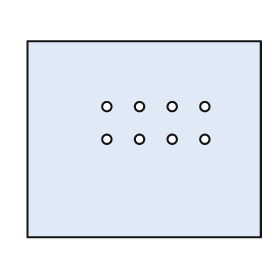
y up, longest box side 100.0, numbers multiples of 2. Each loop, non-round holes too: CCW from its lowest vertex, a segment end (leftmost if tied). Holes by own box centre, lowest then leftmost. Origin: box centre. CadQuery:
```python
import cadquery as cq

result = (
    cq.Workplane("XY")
    .moveTo(-50.0, -42.0)
    .lineTo(50.0, -42.0)
    .lineTo(50.0, 42.0)
    .lineTo(-50.0, 42.0)
    .close()
    .moveTo(-16.0, 0.0)
    .circle(2.0)
    .moveTo(-2.0, 0.0)
    .circle(2.0)
    .moveTo(12.0, 0.0)
    .circle(2.0)
    .moveTo(26.0, 0.0)
    .circle(2.0)
    .moveTo(-16.0, 14.0)
    .circle(2.0)
    .moveTo(-2.0, 14.0)
    .circle(2.0)
    .moveTo(12.0, 14.0)
    .circle(2.0)
    .moveTo(26.0, 14.0)
    .circle(2.0)
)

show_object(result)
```